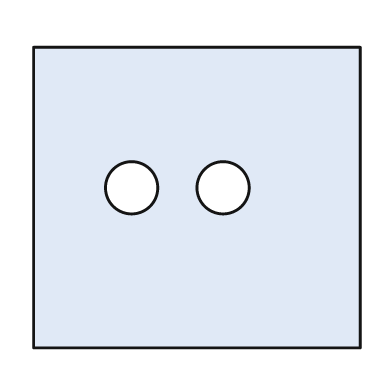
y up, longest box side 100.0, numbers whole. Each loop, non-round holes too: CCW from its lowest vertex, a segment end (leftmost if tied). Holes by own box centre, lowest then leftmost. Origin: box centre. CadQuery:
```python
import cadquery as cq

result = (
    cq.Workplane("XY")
    .moveTo(-50.0, -46.0)
    .lineTo(50.0, -46.0)
    .lineTo(50.0, 46.0)
    .lineTo(-50.0, 46.0)
    .close()
    .moveTo(-20.0, 3.0)
    .circle(8.0)
    .moveTo(8.0, 3.0)
    .circle(8.0)
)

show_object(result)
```